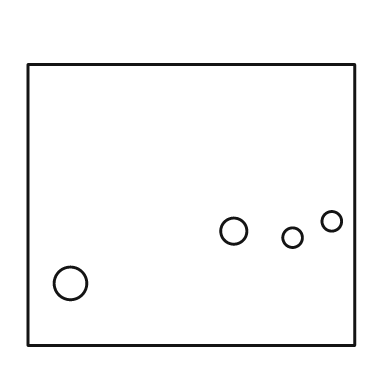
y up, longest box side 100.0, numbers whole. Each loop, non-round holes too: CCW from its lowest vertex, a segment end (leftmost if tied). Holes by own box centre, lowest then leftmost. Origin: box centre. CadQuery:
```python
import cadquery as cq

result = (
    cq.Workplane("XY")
    .moveTo(-50.0, -43.0)
    .lineTo(50.0, -43.0)
    .lineTo(50.0, 43.0)
    .lineTo(-50.0, 43.0)
    .close()
    .moveTo(-37.0, -24.0)
    .circle(5.0)
    .moveTo(31.0, -10.0)
    .circle(3.0)
    .moveTo(13.0, -8.0)
    .circle(4.0)
    .moveTo(43.0, -5.0)
    .circle(3.0)
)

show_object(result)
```